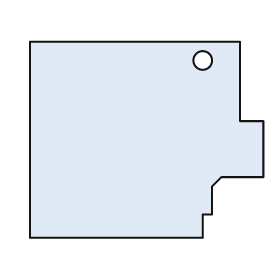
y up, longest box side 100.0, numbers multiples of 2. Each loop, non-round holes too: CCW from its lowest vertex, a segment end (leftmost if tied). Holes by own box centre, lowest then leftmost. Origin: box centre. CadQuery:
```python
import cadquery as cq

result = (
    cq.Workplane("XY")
    .moveTo(-50.0, -42.0)
    .lineTo(24.0, -42.0)
    .lineTo(24.0, -32.0)
    .lineTo(28.0, -32.0)
    .lineTo(28.0, -20.0)
    .lineTo(32.0, -16.0)
    .lineTo(50.0, -16.0)
    .lineTo(50.0, 8.0)
    .lineTo(40.0, 8.0)
    .lineTo(40.0, 42.0)
    .lineTo(-50.0, 42.0)
    .close()
    .moveTo(24.0, 34.0)
    .circle(4.0)
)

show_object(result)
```